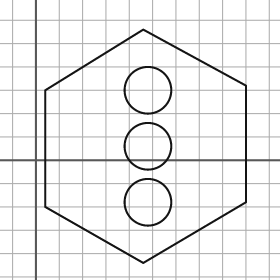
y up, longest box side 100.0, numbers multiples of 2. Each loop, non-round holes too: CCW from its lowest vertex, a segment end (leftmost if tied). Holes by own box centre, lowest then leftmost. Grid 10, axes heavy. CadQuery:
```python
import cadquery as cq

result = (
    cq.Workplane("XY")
    .moveTo(46.0, -44.0)
    .lineTo(90.0, -18.0)
    .lineTo(90.0, 32.0)
    .lineTo(46.0, 56.0)
    .lineTo(4.0, 30.0)
    .lineTo(4.0, -20.0)
    .close()
    .moveTo(48.0, -18.0)
    .circle(10.0)
    .moveTo(48.0, 6.0)
    .circle(10.0)
    .moveTo(48.0, 30.0)
    .circle(10.0)
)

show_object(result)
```